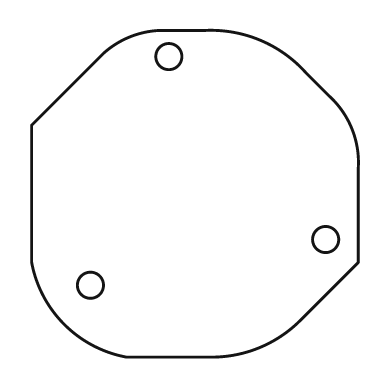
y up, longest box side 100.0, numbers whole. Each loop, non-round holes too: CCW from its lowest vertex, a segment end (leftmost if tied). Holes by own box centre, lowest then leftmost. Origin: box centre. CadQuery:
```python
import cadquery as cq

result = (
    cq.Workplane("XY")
    .moveTo(-21.0, -50.0)
    .lineTo(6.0, -50.0)
    .threePointArc((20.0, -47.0), (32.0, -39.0))
    .lineTo(50.0, -21.0)
    .lineTo(50.0, 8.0)
    .threePointArc((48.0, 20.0), (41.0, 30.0))
    .lineTo(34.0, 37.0)
    .threePointArc((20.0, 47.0), (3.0, 50.0))
    .lineTo(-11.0, 50.0)
    .threePointArc((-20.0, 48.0), (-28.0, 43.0))
    .lineTo(-50.0, 21.0)
    .lineTo(-50.0, -21.0)
    .threePointArc((-40.0, -40.0), (-21.0, -50.0))
    .close()
    .moveTo(-32.0, -28.0)
    .circle(4.0)
    .moveTo(40.0, -14.0)
    .circle(4.0)
    .moveTo(-8.0, 42.0)
    .circle(4.0)
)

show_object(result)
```